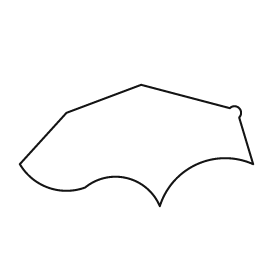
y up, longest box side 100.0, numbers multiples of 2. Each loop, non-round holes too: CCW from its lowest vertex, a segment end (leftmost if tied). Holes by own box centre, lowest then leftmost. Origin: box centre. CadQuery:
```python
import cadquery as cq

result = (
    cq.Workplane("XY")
    .moveTo(10.0, -26.0)
    .threePointArc((26.0, -8.0), (50.0, -8.0))
    .lineTo(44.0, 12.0)
    .threePointArc((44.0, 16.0), (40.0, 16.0))
    .lineTo(2.0, 26.0)
    .lineTo(-30.0, 14.0)
    .lineTo(-50.0, -8.0)
    .threePointArc((-38.0, -18.0), (-22.0, -18.0))
    .threePointArc((-4.0, -14.0), (10.0, -26.0))
    .close()
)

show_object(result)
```